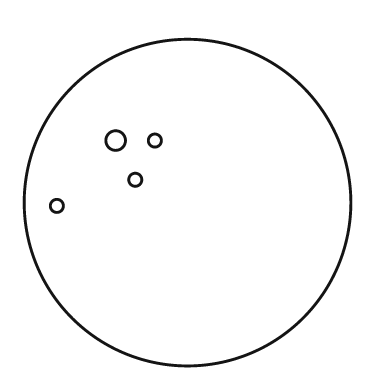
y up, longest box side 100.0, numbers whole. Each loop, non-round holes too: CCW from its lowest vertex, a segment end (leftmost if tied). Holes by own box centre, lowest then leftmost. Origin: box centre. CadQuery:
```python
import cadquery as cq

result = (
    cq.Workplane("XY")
    .moveTo(0.0, 0.0)
    .circle(50.0)
    .moveTo(-40.0, -1.0)
    .circle(2.0)
    .moveTo(-16.0, 7.0)
    .circle(2.0)
    .moveTo(-22.0, 19.0)
    .circle(3.0)
    .moveTo(-10.0, 19.0)
    .circle(2.0)
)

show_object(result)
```